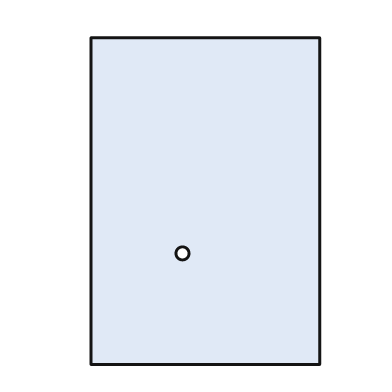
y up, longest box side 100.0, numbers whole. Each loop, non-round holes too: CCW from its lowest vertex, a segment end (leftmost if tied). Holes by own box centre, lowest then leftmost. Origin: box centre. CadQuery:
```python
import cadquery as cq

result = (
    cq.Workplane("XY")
    .moveTo(-35.0, -50.0)
    .lineTo(35.0, -50.0)
    .lineTo(35.0, 50.0)
    .lineTo(-35.0, 50.0)
    .close()
    .moveTo(-7.0, -16.0)
    .circle(2.0)
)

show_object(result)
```